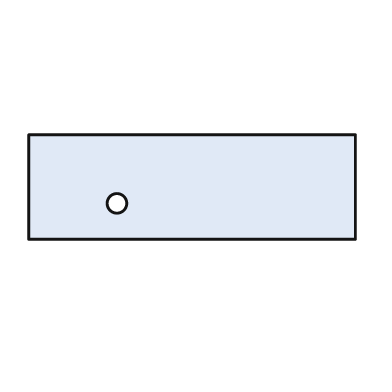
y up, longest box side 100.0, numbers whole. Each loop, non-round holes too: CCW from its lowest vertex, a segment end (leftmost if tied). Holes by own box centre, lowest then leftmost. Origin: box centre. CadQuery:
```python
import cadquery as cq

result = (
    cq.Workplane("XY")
    .moveTo(-50.0, -16.0)
    .lineTo(50.0, -16.0)
    .lineTo(50.0, 16.0)
    .lineTo(-50.0, 16.0)
    .close()
    .moveTo(-23.0, -5.0)
    .circle(3.0)
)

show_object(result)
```